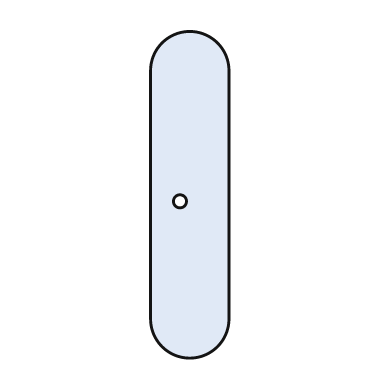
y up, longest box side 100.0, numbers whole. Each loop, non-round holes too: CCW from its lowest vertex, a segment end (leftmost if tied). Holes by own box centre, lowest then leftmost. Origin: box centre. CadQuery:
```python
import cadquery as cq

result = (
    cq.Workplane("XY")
    .moveTo(-12.0, -38.0)
    .threePointArc((0.0, -50.0), (12.0, -38.0))
    .lineTo(12.0, 38.0)
    .threePointArc((0.0, 50.0), (-12.0, 38.0))
    .close()
    .moveTo(-3.0, -2.0)
    .circle(2.0)
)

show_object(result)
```